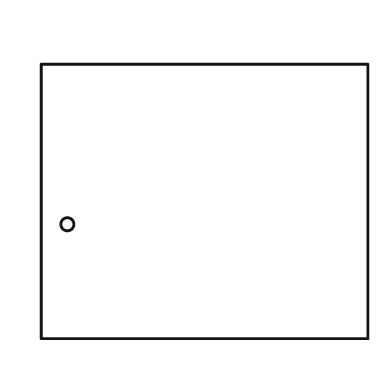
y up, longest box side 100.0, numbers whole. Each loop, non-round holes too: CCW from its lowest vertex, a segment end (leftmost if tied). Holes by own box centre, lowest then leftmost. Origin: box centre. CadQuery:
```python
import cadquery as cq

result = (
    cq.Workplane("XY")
    .moveTo(-50.0, -42.0)
    .lineTo(50.0, -42.0)
    .lineTo(50.0, 42.0)
    .lineTo(-50.0, 42.0)
    .close()
    .moveTo(-42.0, -7.0)
    .circle(2.0)
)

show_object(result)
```